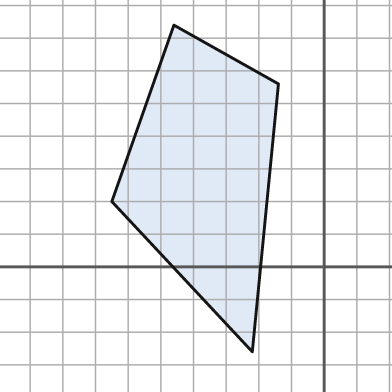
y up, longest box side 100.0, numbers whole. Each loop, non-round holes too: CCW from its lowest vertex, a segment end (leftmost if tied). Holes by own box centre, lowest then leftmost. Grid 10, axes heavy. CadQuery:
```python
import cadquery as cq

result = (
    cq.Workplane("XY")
    .moveTo(-22.0, -26.0)
    .lineTo(-14.0, 56.0)
    .lineTo(-46.0, 74.0)
    .lineTo(-65.0, 20.0)
    .close()
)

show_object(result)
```